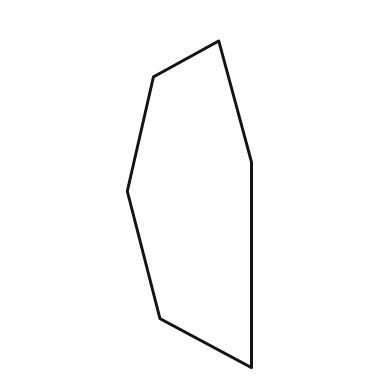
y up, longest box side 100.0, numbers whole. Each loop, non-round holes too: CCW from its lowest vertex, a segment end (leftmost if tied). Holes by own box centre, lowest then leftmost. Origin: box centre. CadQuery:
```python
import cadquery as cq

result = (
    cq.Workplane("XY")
    .moveTo(19.0, -50.0)
    .lineTo(19.0, 13.0)
    .lineTo(9.0, 50.0)
    .lineTo(-11.0, 39.0)
    .lineTo(-19.0, 4.0)
    .lineTo(-9.0, -35.0)
    .close()
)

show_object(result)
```